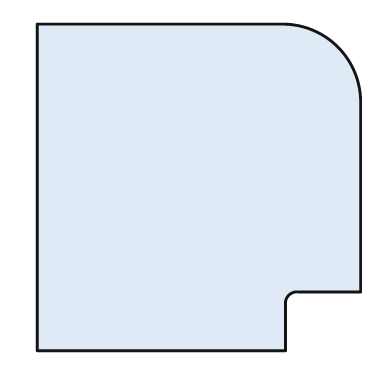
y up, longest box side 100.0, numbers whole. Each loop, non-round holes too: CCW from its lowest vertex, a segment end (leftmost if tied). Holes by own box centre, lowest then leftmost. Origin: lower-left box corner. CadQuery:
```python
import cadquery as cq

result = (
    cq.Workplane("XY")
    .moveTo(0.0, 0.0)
    .lineTo(76.0, 0.0)
    .lineTo(76.0, 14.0)
    .threePointArc((77.0, 17.0), (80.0, 18.0))
    .lineTo(99.0, 18.0)
    .lineTo(99.0, 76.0)
    .threePointArc((92.0, 93.0), (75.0, 100.0))
    .lineTo(0.0, 100.0)
    .close()
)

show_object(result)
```